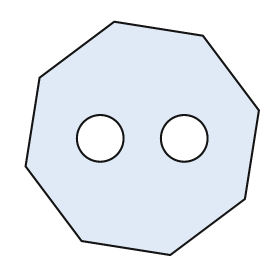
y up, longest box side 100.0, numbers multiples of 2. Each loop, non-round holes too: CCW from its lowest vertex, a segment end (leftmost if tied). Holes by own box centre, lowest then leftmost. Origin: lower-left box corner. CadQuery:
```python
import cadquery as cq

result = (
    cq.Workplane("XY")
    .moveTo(62.0, 0.0)
    .lineTo(94.0, 24.0)
    .lineTo(100.0, 62.0)
    .lineTo(76.0, 94.0)
    .lineTo(38.0, 100.0)
    .lineTo(6.0, 76.0)
    .lineTo(0.0, 38.0)
    .lineTo(24.0, 6.0)
    .close()
    .moveTo(32.0, 50.0)
    .circle(10.0)
    .moveTo(68.0, 50.0)
    .circle(10.0)
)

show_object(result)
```